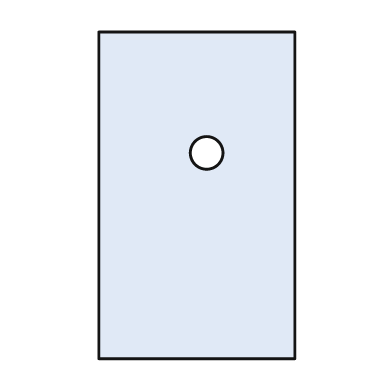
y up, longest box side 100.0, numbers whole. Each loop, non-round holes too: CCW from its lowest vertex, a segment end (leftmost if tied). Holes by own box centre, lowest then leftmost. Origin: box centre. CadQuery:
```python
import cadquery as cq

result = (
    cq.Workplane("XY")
    .moveTo(-30.0, -50.0)
    .lineTo(30.0, -50.0)
    .lineTo(30.0, 50.0)
    .lineTo(-30.0, 50.0)
    .close()
    .moveTo(3.0, 13.0)
    .circle(5.0)
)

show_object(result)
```